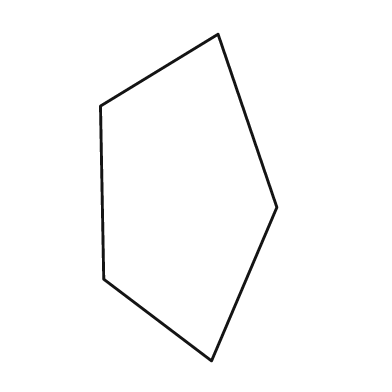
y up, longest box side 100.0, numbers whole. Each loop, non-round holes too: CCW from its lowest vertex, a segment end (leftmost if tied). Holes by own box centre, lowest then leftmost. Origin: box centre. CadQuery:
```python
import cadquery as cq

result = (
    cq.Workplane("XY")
    .moveTo(7.0, -50.0)
    .lineTo(27.0, -3.0)
    .lineTo(9.0, 50.0)
    .lineTo(-27.0, 28.0)
    .lineTo(-26.0, -25.0)
    .close()
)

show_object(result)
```